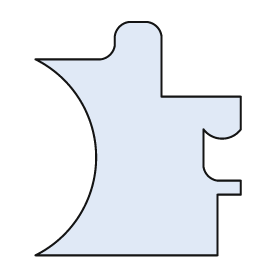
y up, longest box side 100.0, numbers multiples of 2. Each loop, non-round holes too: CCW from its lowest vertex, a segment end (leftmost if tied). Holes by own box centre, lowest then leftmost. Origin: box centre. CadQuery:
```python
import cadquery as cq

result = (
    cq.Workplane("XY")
    .moveTo(-44.0, -50.0)
    .lineTo(34.0, -50.0)
    .lineTo(34.0, -24.0)
    .lineTo(44.0, -24.0)
    .lineTo(44.0, -18.0)
    .lineTo(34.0, -18.0)
    .threePointArc((30.0, -16.0), (28.0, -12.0))
    .lineTo(28.0, 4.0)
    .threePointArc((36.0, 0.0), (44.0, 4.0))
    .lineTo(44.0, 18.0)
    .lineTo(10.0, 18.0)
    .lineTo(10.0, 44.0)
    .threePointArc((8.0, 48.0), (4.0, 50.0))
    .lineTo(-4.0, 50.0)
    .threePointArc((-8.0, 48.0), (-10.0, 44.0))
    .lineTo(-10.0, 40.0)
    .threePointArc((-12.0, 36.0), (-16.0, 34.0))
    .lineTo(-44.0, 34.0)
    .threePointArc((-18.0, -8.0), (-44.0, -50.0))
    .close()
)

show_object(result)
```